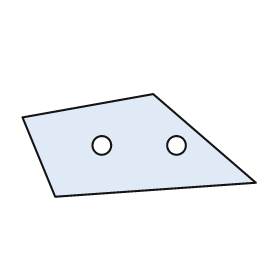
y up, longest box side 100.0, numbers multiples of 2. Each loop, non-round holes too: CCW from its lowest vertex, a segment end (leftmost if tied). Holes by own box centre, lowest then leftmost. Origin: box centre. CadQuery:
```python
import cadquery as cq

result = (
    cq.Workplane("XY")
    .moveTo(-36.0, -22.0)
    .lineTo(50.0, -16.0)
    .lineTo(6.0, 22.0)
    .lineTo(-50.0, 12.0)
    .close()
    .moveTo(-16.0, 0.0)
    .circle(4.0)
    .moveTo(16.0, 0.0)
    .circle(4.0)
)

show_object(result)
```